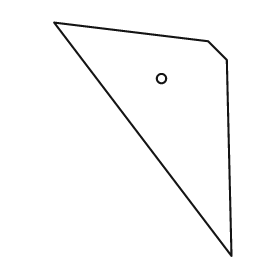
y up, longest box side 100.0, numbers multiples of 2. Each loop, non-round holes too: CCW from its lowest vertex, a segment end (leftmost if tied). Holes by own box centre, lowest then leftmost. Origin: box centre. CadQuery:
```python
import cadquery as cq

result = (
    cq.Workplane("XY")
    .moveTo(38.0, -50.0)
    .lineTo(36.0, 34.0)
    .lineTo(28.0, 42.0)
    .lineTo(-38.0, 50.0)
    .close()
    .moveTo(8.0, 26.0)
    .circle(2.0)
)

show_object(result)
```